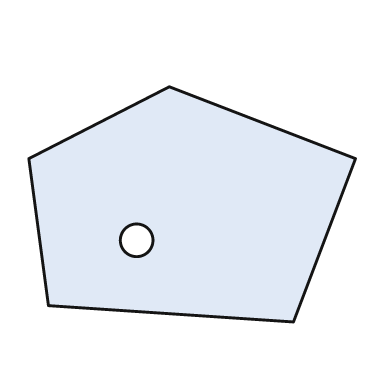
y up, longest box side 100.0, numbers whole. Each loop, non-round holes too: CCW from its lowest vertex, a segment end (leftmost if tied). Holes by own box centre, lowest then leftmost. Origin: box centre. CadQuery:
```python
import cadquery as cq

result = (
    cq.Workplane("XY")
    .moveTo(31.0, -36.0)
    .lineTo(50.0, 14.0)
    .lineTo(-7.0, 36.0)
    .lineTo(-50.0, 14.0)
    .lineTo(-44.0, -31.0)
    .close()
    .moveTo(-17.0, -11.0)
    .circle(5.0)
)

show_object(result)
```